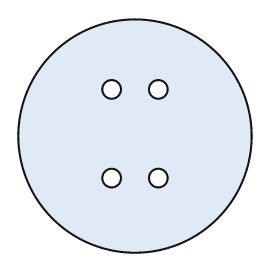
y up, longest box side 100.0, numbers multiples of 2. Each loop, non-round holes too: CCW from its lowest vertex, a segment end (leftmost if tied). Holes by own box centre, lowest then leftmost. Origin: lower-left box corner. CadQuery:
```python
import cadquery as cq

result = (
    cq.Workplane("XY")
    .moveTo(50.0, 50.0)
    .circle(50.0)
    .moveTo(40.0, 32.0)
    .circle(4.0)
    .moveTo(60.0, 32.0)
    .circle(4.0)
    .moveTo(40.0, 70.0)
    .circle(4.0)
    .moveTo(60.0, 70.0)
    .circle(4.0)
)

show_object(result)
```